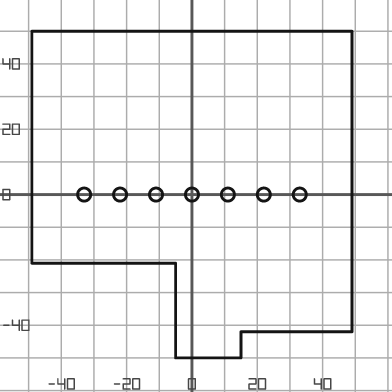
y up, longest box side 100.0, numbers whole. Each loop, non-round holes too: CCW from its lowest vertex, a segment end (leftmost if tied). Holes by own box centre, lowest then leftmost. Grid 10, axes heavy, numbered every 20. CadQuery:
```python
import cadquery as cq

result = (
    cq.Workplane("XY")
    .moveTo(-5.0, -50.0)
    .lineTo(15.0, -50.0)
    .lineTo(15.0, -42.0)
    .lineTo(49.0, -42.0)
    .lineTo(49.0, 50.0)
    .lineTo(-49.0, 50.0)
    .lineTo(-49.0, -21.0)
    .lineTo(-5.0, -21.0)
    .close()
    .moveTo(-33.0, 0.0)
    .circle(2.0)
    .moveTo(-22.0, 0.0)
    .circle(2.0)
    .moveTo(-11.0, 0.0)
    .circle(2.0)
    .moveTo(0.0, 0.0)
    .circle(2.0)
    .moveTo(11.0, 0.0)
    .circle(2.0)
    .moveTo(22.0, 0.0)
    .circle(2.0)
    .moveTo(33.0, 0.0)
    .circle(2.0)
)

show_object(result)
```